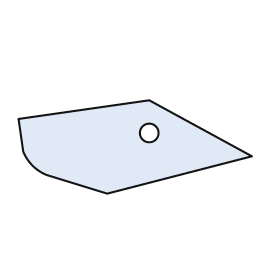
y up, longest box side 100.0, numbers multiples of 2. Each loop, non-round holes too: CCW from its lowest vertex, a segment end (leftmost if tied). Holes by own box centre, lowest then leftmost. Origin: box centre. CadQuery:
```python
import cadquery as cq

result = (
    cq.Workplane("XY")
    .moveTo(-12.0, -20.0)
    .lineTo(50.0, -4.0)
    .lineTo(6.0, 20.0)
    .lineTo(-50.0, 12.0)
    .lineTo(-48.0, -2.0)
    .threePointArc((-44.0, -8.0), (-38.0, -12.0))
    .close()
    .moveTo(6.0, 6.0)
    .circle(4.0)
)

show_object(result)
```